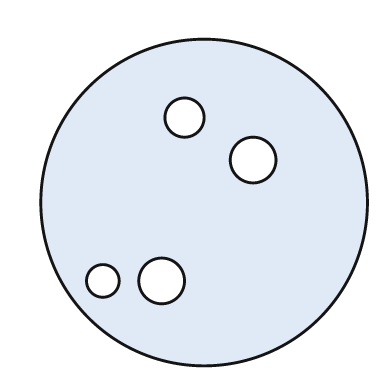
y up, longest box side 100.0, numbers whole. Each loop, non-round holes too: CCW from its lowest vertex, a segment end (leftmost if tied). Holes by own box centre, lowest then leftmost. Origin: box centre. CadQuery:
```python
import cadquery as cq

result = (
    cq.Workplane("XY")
    .moveTo(0.0, 0.0)
    .circle(50.0)
    .moveTo(-31.0, -24.0)
    .circle(5.0)
    .moveTo(-13.0, -24.0)
    .circle(7.0)
    .moveTo(15.0, 13.0)
    .circle(7.0)
    .moveTo(-6.0, 26.0)
    .circle(6.0)
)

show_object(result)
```